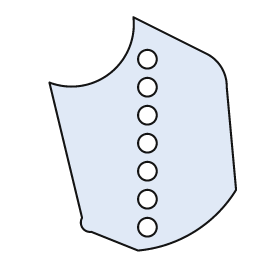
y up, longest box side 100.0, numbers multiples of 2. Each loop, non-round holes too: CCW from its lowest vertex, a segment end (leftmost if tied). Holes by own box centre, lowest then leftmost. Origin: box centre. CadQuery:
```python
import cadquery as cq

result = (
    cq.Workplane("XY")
    .moveTo(-2.0, -50.0)
    .threePointArc((22.0, -42.0), (40.0, -24.0))
    .lineTo(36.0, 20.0)
    .threePointArc((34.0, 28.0), (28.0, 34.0))
    .lineTo(-4.0, 50.0)
    .threePointArc((-14.0, 26.0), (-40.0, 22.0))
    .lineTo(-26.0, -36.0)
    .threePointArc((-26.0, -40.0), (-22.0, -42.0))
    .close()
    .moveTo(2.0, -40.0)
    .circle(4.0)
    .moveTo(2.0, -28.0)
    .circle(4.0)
    .moveTo(2.0, -16.0)
    .circle(4.0)
    .moveTo(2.0, -4.0)
    .circle(4.0)
    .moveTo(2.0, 8.0)
    .circle(4.0)
    .moveTo(2.0, 20.0)
    .circle(4.0)
    .moveTo(2.0, 32.0)
    .circle(4.0)
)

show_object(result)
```